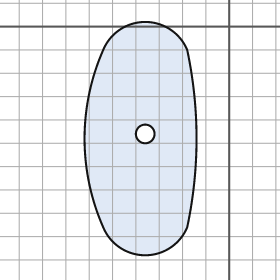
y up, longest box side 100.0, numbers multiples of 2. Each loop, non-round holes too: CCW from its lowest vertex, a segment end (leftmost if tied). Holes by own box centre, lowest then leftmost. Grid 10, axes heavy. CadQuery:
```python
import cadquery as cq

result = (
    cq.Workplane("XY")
    .moveTo(-54.0, -86.0)
    .threePointArc((-36.0, -98.0), (-18.0, -86.0))
    .threePointArc((-14.0, -48.0), (-18.0, -10.0))
    .threePointArc((-36.0, 2.0), (-54.0, -10.0))
    .threePointArc((-62.0, -48.0), (-54.0, -86.0))
    .close()
    .moveTo(-36.0, -46.0)
    .circle(4.0)
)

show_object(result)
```